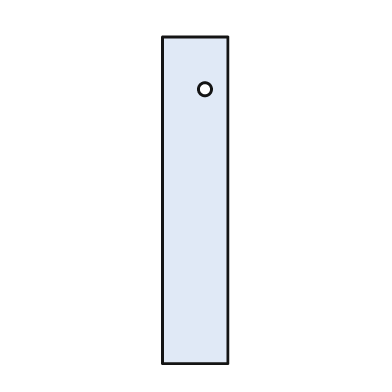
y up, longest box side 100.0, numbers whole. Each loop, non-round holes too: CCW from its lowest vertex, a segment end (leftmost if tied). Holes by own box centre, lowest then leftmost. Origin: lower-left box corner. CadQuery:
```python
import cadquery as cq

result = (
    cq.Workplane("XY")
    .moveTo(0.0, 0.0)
    .lineTo(20.0, 0.0)
    .lineTo(20.0, 100.0)
    .lineTo(0.0, 100.0)
    .close()
    .moveTo(13.0, 84.0)
    .circle(2.0)
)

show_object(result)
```